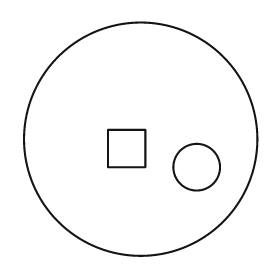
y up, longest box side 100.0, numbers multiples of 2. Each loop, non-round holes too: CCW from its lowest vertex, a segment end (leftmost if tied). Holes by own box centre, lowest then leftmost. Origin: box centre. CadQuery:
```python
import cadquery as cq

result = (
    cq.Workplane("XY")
    .moveTo(0.0, 0.0)
    .circle(50.0)
    .moveTo(24.0, -12.0)
    .circle(10.0)
    .moveTo(-14.0, -12.0)
    .lineTo(2.0, -12.0)
    .lineTo(2.0, 4.0)
    .lineTo(-14.0, 4.0)
    .close()
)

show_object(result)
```